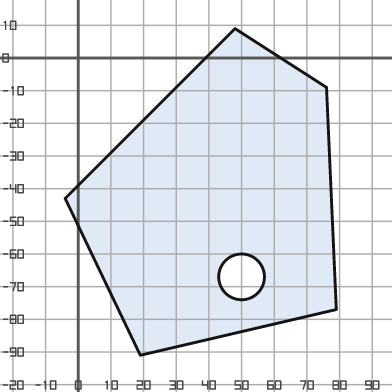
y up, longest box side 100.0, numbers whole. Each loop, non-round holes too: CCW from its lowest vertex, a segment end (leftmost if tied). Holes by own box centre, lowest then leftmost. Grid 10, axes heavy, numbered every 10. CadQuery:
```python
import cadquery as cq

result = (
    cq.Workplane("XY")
    .moveTo(19.0, -91.0)
    .lineTo(79.0, -77.0)
    .lineTo(76.0, -9.0)
    .lineTo(48.0, 9.0)
    .lineTo(-4.0, -43.0)
    .close()
    .moveTo(50.0, -67.0)
    .circle(7.0)
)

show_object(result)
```